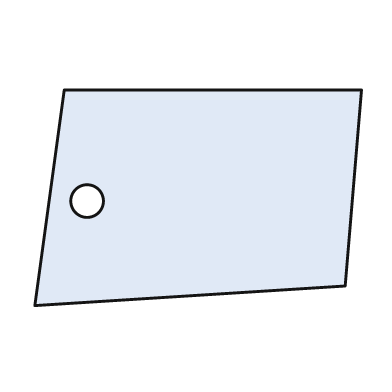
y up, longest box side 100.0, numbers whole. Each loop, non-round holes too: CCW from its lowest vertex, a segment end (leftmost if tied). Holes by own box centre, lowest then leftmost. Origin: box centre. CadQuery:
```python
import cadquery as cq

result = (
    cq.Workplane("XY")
    .moveTo(-50.0, -33.0)
    .lineTo(45.0, -27.0)
    .lineTo(50.0, 33.0)
    .lineTo(-41.0, 33.0)
    .close()
    .moveTo(-34.0, -1.0)
    .circle(5.0)
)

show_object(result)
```